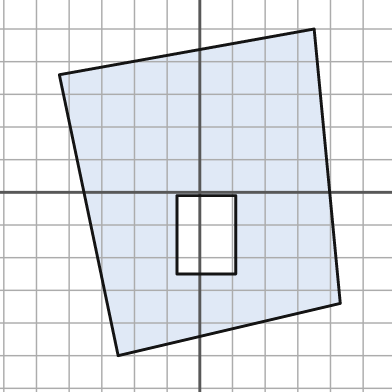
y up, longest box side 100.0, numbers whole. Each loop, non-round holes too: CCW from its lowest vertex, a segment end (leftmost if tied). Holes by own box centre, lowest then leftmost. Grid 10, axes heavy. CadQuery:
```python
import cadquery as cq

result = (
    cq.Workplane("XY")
    .moveTo(-25.0, -50.0)
    .lineTo(43.0, -34.0)
    .lineTo(35.0, 50.0)
    .lineTo(-43.0, 36.0)
    .close()
    .moveTo(-7.0, -25.0)
    .lineTo(11.0, -25.0)
    .lineTo(11.0, -1.0)
    .lineTo(-7.0, -1.0)
    .close()
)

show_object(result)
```